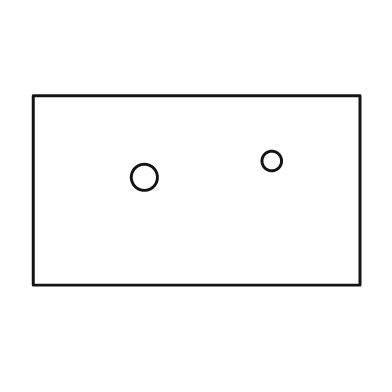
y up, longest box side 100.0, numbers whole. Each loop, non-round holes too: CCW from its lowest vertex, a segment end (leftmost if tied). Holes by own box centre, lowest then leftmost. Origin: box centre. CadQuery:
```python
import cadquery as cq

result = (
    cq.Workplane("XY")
    .moveTo(-50.0, -29.0)
    .lineTo(50.0, -29.0)
    .lineTo(50.0, 29.0)
    .lineTo(-50.0, 29.0)
    .close()
    .moveTo(-16.0, 4.0)
    .circle(4.0)
    .moveTo(23.0, 9.0)
    .circle(3.0)
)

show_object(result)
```